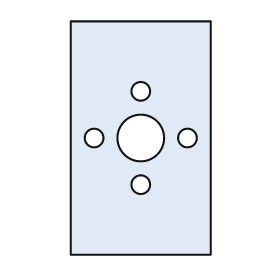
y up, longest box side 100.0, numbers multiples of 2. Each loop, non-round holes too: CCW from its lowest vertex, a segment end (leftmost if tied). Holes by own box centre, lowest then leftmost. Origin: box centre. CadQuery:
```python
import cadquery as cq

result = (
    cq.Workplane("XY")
    .moveTo(-30.0, -50.0)
    .lineTo(30.0, -50.0)
    .lineTo(30.0, 50.0)
    .lineTo(-30.0, 50.0)
    .close()
    .moveTo(0.0, -20.0)
    .circle(4.0)
    .moveTo(-20.0, 0.0)
    .circle(4.0)
    .moveTo(0.0, 0.0)
    .circle(10.0)
    .moveTo(20.0, 0.0)
    .circle(4.0)
    .moveTo(0.0, 20.0)
    .circle(4.0)
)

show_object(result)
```